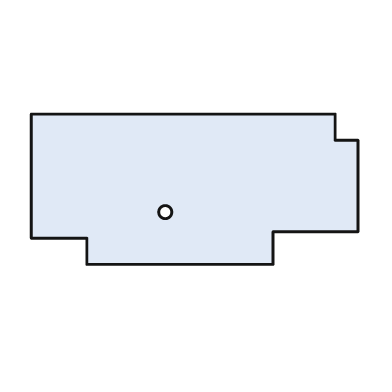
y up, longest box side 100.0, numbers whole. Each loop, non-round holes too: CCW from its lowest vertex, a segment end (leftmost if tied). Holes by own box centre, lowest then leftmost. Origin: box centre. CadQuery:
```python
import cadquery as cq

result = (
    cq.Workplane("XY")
    .moveTo(-33.0, -23.0)
    .lineTo(24.0, -23.0)
    .lineTo(24.0, -13.0)
    .lineTo(50.0, -13.0)
    .lineTo(50.0, 15.0)
    .lineTo(43.0, 15.0)
    .lineTo(43.0, 23.0)
    .lineTo(-50.0, 23.0)
    .lineTo(-50.0, -15.0)
    .lineTo(-33.0, -15.0)
    .close()
    .moveTo(-9.0, -7.0)
    .circle(2.0)
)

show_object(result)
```